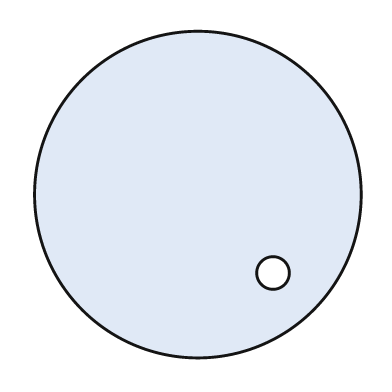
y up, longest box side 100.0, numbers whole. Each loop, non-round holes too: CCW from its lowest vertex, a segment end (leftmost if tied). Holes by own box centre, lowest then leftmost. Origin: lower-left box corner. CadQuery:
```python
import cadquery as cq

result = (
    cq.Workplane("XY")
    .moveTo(50.0, 50.0)
    .circle(50.0)
    .moveTo(73.0, 26.0)
    .circle(5.0)
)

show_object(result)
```